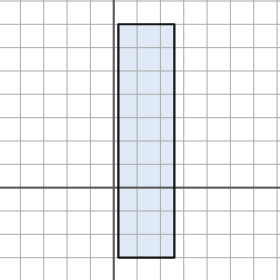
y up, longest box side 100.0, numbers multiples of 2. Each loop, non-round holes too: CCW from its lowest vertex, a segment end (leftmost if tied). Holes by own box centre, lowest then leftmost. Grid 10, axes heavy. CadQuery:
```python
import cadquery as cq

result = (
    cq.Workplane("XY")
    .moveTo(2.0, -30.0)
    .lineTo(26.0, -30.0)
    .lineTo(26.0, 70.0)
    .lineTo(2.0, 70.0)
    .close()
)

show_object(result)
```